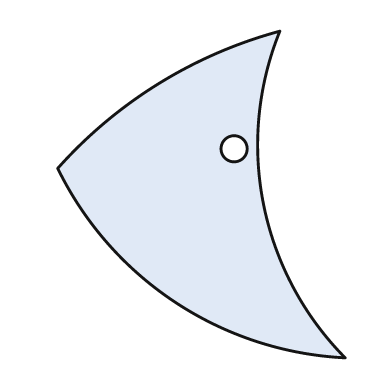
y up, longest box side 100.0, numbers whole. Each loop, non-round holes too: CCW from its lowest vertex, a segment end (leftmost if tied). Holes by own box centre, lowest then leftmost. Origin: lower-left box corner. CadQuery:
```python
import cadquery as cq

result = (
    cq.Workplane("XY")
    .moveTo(88.0, 0.0)
    .threePointArc((63.0, 47.0), (68.0, 100.0))
    .threePointArc((31.0, 84.0), (0.0, 58.0))
    .threePointArc((36.0, 17.0), (88.0, 0.0))
    .close()
    .moveTo(54.0, 64.0)
    .circle(4.0)
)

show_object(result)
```